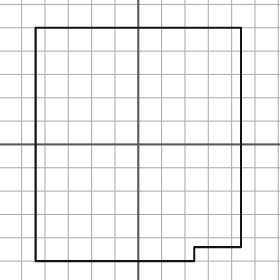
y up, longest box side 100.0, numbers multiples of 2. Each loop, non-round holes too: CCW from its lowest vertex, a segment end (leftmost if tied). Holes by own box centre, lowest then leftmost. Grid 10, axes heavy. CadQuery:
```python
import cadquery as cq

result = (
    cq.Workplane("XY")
    .moveTo(-44.0, -50.0)
    .lineTo(24.0, -50.0)
    .lineTo(24.0, -44.0)
    .lineTo(44.0, -44.0)
    .lineTo(44.0, 50.0)
    .lineTo(-44.0, 50.0)
    .close()
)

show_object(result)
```